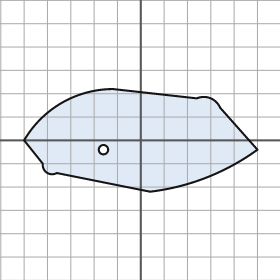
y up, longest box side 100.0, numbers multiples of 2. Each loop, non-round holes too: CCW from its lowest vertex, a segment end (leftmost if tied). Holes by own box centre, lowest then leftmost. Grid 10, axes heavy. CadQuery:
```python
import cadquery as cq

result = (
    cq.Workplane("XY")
    .moveTo(4.0, -22.0)
    .threePointArc((28.0, -16.0), (50.0, -4.0))
    .lineTo(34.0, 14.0)
    .threePointArc((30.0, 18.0), (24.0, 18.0))
    .lineTo(-12.0, 22.0)
    .threePointArc((-34.0, 16.0), (-50.0, 0.0))
    .lineTo(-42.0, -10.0)
    .threePointArc((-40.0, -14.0), (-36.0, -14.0))
    .close()
    .moveTo(-16.0, -4.0)
    .circle(2.0)
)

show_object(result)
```